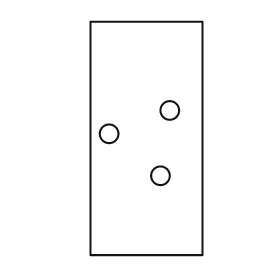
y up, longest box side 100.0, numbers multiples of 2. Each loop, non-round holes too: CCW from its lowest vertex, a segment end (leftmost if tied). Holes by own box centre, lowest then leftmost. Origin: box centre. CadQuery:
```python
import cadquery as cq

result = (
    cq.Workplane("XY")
    .moveTo(-24.0, -50.0)
    .lineTo(24.0, -50.0)
    .lineTo(24.0, 50.0)
    .lineTo(-24.0, 50.0)
    .close()
    .moveTo(6.0, -16.0)
    .circle(4.0)
    .moveTo(-16.0, 2.0)
    .circle(4.0)
    .moveTo(10.0, 12.0)
    .circle(4.0)
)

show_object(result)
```